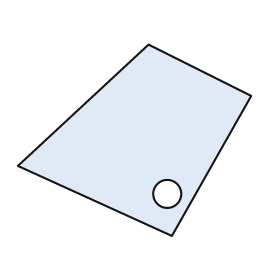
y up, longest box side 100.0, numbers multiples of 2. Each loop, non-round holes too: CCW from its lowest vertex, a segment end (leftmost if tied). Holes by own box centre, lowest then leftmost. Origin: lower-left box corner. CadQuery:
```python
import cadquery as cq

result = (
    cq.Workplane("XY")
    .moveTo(66.0, 0.0)
    .lineTo(100.0, 60.0)
    .lineTo(56.0, 82.0)
    .lineTo(0.0, 30.0)
    .close()
    .moveTo(64.0, 18.0)
    .circle(6.0)
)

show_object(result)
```